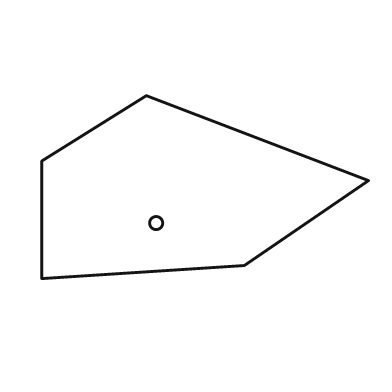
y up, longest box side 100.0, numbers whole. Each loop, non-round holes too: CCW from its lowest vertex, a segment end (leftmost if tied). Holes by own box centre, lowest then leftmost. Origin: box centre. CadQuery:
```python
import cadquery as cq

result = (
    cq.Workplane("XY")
    .moveTo(-50.0, -28.0)
    .lineTo(12.0, -24.0)
    .lineTo(50.0, 2.0)
    .lineTo(-18.0, 28.0)
    .lineTo(-50.0, 8.0)
    .close()
    .moveTo(-15.0, -11.0)
    .circle(2.0)
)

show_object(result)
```